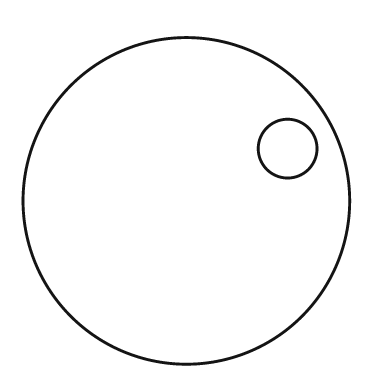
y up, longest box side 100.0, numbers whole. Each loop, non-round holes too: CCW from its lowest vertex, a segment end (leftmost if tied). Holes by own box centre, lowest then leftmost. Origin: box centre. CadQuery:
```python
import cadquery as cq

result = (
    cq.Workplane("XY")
    .moveTo(0.0, 0.0)
    .circle(50.0)
    .moveTo(31.0, 16.0)
    .circle(9.0)
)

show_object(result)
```